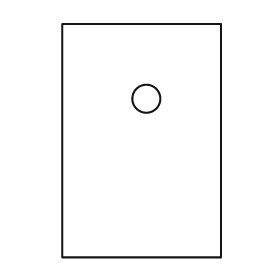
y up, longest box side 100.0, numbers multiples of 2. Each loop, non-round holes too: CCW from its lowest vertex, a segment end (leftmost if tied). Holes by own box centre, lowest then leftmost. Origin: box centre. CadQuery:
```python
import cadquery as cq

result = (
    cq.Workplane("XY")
    .moveTo(-34.0, -50.0)
    .lineTo(34.0, -50.0)
    .lineTo(34.0, 50.0)
    .lineTo(-34.0, 50.0)
    .close()
    .moveTo(2.0, 18.0)
    .circle(6.0)
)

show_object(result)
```